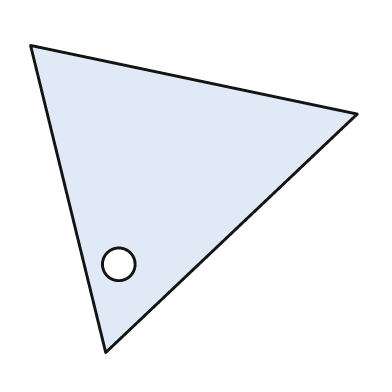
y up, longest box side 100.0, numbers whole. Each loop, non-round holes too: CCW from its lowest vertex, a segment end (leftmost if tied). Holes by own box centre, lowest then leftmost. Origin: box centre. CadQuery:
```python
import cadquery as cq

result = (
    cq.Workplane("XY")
    .moveTo(-27.0, -47.0)
    .lineTo(50.0, 26.0)
    .lineTo(-50.0, 47.0)
    .close()
    .moveTo(-23.0, -20.0)
    .circle(5.0)
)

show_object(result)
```